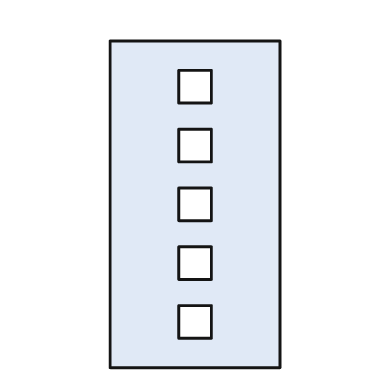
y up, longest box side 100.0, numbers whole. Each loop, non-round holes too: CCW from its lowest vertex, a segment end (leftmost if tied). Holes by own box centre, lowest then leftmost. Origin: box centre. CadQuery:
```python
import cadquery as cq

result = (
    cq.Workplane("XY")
    .moveTo(-26.0, -50.0)
    .lineTo(26.0, -50.0)
    .lineTo(26.0, 50.0)
    .lineTo(-26.0, 50.0)
    .close()
    .moveTo(-5.0, -41.0)
    .lineTo(5.0, -41.0)
    .lineTo(5.0, -31.0)
    .lineTo(-5.0, -31.0)
    .close()
    .moveTo(-5.0, -23.0)
    .lineTo(5.0, -23.0)
    .lineTo(5.0, -13.0)
    .lineTo(-5.0, -13.0)
    .close()
    .moveTo(-5.0, -5.0)
    .lineTo(5.0, -5.0)
    .lineTo(5.0, 5.0)
    .lineTo(-5.0, 5.0)
    .close()
    .moveTo(-5.0, 13.0)
    .lineTo(5.0, 13.0)
    .lineTo(5.0, 23.0)
    .lineTo(-5.0, 23.0)
    .close()
    .moveTo(-5.0, 31.0)
    .lineTo(5.0, 31.0)
    .lineTo(5.0, 41.0)
    .lineTo(-5.0, 41.0)
    .close()
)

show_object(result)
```